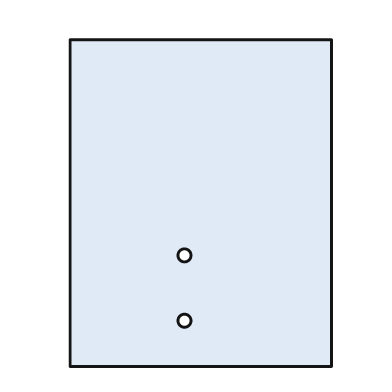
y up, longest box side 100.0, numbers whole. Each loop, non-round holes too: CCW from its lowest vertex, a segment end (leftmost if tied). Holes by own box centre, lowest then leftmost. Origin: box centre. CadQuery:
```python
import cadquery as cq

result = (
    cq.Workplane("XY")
    .moveTo(-40.0, -50.0)
    .lineTo(40.0, -50.0)
    .lineTo(40.0, 50.0)
    .lineTo(-40.0, 50.0)
    .close()
    .moveTo(-5.0, -36.0)
    .circle(2.0)
    .moveTo(-5.0, -16.0)
    .circle(2.0)
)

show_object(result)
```